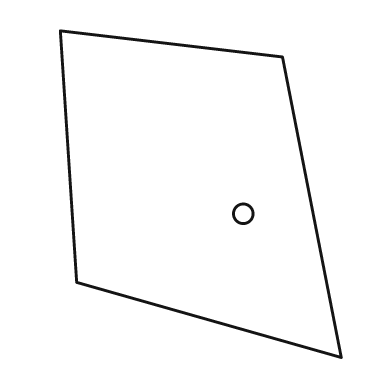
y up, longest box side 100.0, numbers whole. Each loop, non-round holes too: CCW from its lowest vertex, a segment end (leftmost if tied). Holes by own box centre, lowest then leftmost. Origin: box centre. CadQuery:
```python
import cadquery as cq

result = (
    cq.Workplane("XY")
    .moveTo(43.0, -50.0)
    .lineTo(25.0, 42.0)
    .lineTo(-43.0, 50.0)
    .lineTo(-38.0, -27.0)
    .close()
    .moveTo(13.0, -6.0)
    .circle(3.0)
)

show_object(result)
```